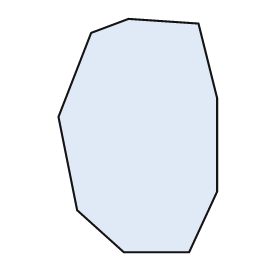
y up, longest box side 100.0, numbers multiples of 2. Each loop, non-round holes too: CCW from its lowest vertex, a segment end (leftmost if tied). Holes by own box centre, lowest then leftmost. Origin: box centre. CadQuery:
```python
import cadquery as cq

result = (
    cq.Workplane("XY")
    .moveTo(-6.0, -50.0)
    .lineTo(22.0, -50.0)
    .lineTo(34.0, -24.0)
    .lineTo(34.0, 16.0)
    .lineTo(26.0, 48.0)
    .lineTo(-4.0, 50.0)
    .lineTo(-20.0, 44.0)
    .lineTo(-34.0, 8.0)
    .lineTo(-26.0, -32.0)
    .close()
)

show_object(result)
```